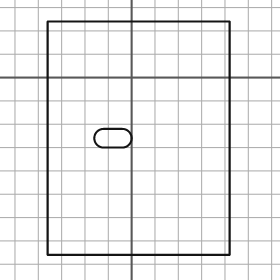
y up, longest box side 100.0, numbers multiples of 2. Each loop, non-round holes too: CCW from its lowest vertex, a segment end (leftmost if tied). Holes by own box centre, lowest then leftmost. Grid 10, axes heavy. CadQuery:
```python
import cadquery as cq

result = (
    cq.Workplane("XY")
    .moveTo(-36.0, -76.0)
    .lineTo(42.0, -76.0)
    .lineTo(42.0, 24.0)
    .lineTo(-36.0, 24.0)
    .close()
    .moveTo(-12.0, -30.0)
    .lineTo(-4.0, -30.0)
    .threePointArc((0.0, -26.0), (-4.0, -22.0))
    .lineTo(-12.0, -22.0)
    .threePointArc((-16.0, -26.0), (-12.0, -30.0))
    .close()
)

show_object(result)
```